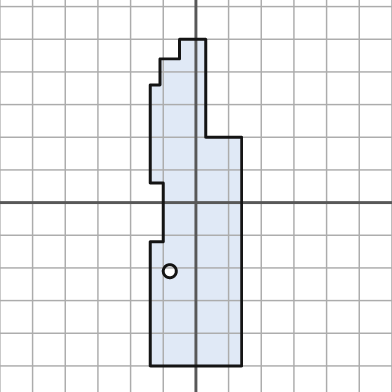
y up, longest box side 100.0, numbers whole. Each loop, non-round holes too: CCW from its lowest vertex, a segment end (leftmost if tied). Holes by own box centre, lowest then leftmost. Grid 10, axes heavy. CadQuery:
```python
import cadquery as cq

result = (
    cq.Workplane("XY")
    .moveTo(-14.0, -50.0)
    .lineTo(14.0, -50.0)
    .lineTo(14.0, 20.0)
    .lineTo(3.0, 20.0)
    .lineTo(3.0, 50.0)
    .lineTo(-5.0, 50.0)
    .lineTo(-5.0, 44.0)
    .lineTo(-11.0, 44.0)
    .lineTo(-11.0, 36.0)
    .lineTo(-14.0, 36.0)
    .lineTo(-14.0, 6.0)
    .lineTo(-10.0, 6.0)
    .lineTo(-10.0, -12.0)
    .lineTo(-14.0, -12.0)
    .close()
    .moveTo(-8.0, -21.0)
    .circle(2.0)
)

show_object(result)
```